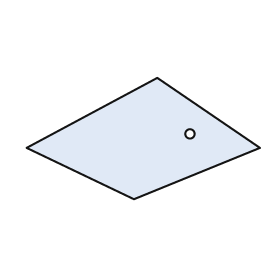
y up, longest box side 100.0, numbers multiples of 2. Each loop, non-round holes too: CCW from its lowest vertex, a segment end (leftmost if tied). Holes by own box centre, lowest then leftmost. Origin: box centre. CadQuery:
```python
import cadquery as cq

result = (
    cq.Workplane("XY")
    .moveTo(-4.0, -26.0)
    .lineTo(50.0, -4.0)
    .lineTo(6.0, 26.0)
    .lineTo(-50.0, -4.0)
    .close()
    .moveTo(20.0, 2.0)
    .circle(2.0)
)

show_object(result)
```